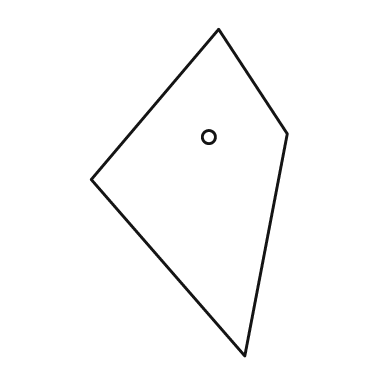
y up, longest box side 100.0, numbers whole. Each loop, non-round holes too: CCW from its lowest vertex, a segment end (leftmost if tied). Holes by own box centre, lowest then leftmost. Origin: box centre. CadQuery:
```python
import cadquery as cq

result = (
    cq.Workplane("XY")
    .moveTo(17.0, -50.0)
    .lineTo(30.0, 18.0)
    .lineTo(9.0, 50.0)
    .lineTo(-30.0, 4.0)
    .close()
    .moveTo(6.0, 17.0)
    .circle(2.0)
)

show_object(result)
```